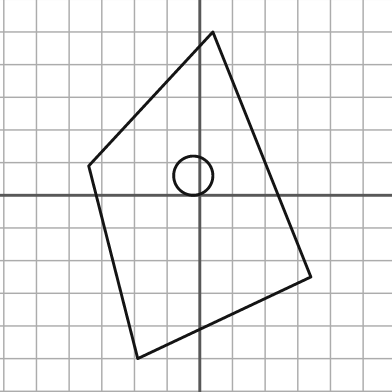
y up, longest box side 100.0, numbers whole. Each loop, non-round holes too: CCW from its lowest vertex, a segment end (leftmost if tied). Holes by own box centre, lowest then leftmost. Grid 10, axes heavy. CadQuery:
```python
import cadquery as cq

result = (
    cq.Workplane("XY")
    .moveTo(-19.0, -50.0)
    .lineTo(34.0, -25.0)
    .lineTo(4.0, 50.0)
    .lineTo(-34.0, 9.0)
    .close()
    .moveTo(-2.0, 6.0)
    .circle(6.0)
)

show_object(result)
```